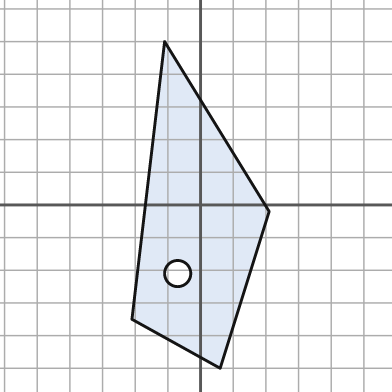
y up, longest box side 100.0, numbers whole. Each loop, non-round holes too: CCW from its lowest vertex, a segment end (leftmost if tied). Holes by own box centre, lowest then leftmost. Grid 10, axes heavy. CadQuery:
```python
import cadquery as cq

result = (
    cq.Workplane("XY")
    .moveTo(6.0, -50.0)
    .lineTo(21.0, -2.0)
    .lineTo(-11.0, 50.0)
    .lineTo(-21.0, -35.0)
    .close()
    .moveTo(-7.0, -21.0)
    .circle(4.0)
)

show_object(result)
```